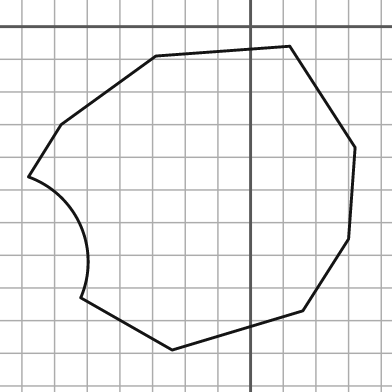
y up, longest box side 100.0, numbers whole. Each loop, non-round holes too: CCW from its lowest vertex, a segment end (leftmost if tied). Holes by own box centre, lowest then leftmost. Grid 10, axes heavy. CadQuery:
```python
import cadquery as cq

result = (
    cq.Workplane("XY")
    .moveTo(-24.0, -99.0)
    .lineTo(16.0, -87.0)
    .lineTo(30.0, -65.0)
    .lineTo(32.0, -37.0)
    .lineTo(12.0, -6.0)
    .lineTo(-29.0, -9.0)
    .lineTo(-58.0, -30.0)
    .lineTo(-68.0, -46.0)
    .threePointArc((-52.0, -61.0), (-52.0, -83.0))
    .close()
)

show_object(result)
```